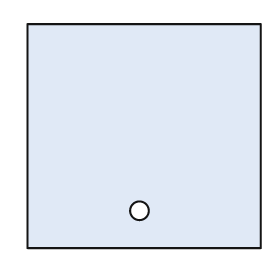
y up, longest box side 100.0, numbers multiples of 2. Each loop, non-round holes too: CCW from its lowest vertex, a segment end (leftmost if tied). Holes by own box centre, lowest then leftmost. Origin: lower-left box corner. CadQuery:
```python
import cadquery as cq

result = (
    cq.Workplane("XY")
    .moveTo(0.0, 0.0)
    .lineTo(100.0, 0.0)
    .lineTo(100.0, 96.0)
    .lineTo(0.0, 96.0)
    .close()
    .moveTo(48.0, 16.0)
    .circle(4.0)
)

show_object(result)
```